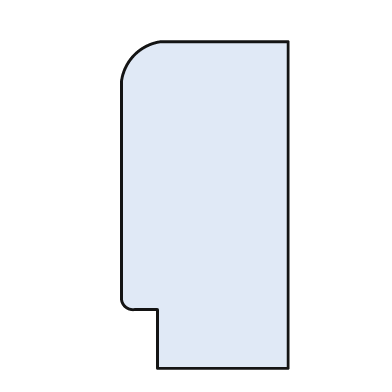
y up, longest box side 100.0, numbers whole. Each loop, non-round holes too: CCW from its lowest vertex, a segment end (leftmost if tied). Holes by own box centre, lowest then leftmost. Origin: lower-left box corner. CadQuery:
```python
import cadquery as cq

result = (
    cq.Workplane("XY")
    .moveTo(11.0, 0.0)
    .lineTo(51.0, 0.0)
    .lineTo(51.0, 100.0)
    .lineTo(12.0, 100.0)
    .threePointArc((4.0, 96.0), (0.0, 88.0))
    .lineTo(0.0, 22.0)
    .threePointArc((1.0, 19.0), (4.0, 18.0))
    .lineTo(11.0, 18.0)
    .close()
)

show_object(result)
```